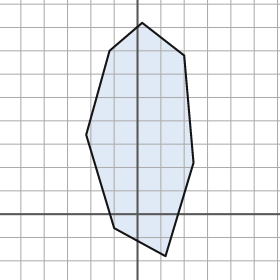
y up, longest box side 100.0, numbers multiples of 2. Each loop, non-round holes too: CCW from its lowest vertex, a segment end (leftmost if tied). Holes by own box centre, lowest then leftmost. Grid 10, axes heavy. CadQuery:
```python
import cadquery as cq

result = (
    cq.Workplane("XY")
    .moveTo(12.0, -18.0)
    .lineTo(24.0, 22.0)
    .lineTo(20.0, 68.0)
    .lineTo(2.0, 82.0)
    .lineTo(-12.0, 70.0)
    .lineTo(-22.0, 34.0)
    .lineTo(-10.0, -6.0)
    .close()
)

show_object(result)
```